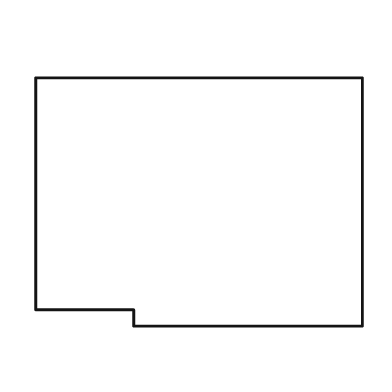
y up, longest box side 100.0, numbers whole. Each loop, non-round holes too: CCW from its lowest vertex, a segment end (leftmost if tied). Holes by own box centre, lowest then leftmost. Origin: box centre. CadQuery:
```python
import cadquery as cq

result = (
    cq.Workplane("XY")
    .moveTo(-20.0, -38.0)
    .lineTo(50.0, -38.0)
    .lineTo(50.0, 38.0)
    .lineTo(-50.0, 38.0)
    .lineTo(-50.0, -33.0)
    .lineTo(-20.0, -33.0)
    .close()
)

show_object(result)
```